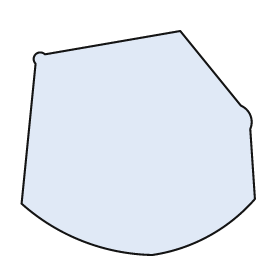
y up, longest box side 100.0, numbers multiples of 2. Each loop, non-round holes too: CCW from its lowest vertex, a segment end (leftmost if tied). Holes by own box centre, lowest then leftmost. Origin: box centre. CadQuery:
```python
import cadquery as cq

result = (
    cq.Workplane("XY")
    .moveTo(6.0, -48.0)
    .threePointArc((30.0, -40.0), (50.0, -24.0))
    .lineTo(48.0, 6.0)
    .threePointArc((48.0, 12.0), (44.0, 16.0))
    .lineTo(18.0, 48.0)
    .lineTo(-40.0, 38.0)
    .threePointArc((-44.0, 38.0), (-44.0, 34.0))
    .lineTo(-50.0, -26.0)
    .threePointArc((-24.0, -42.0), (6.0, -48.0))
    .close()
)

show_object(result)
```